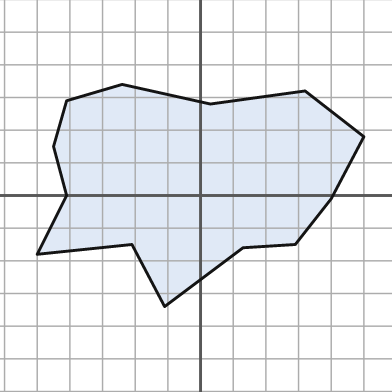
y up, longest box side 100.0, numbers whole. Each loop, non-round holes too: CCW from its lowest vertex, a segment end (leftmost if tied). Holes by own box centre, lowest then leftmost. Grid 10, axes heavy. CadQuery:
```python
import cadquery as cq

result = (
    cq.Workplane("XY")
    .moveTo(-11.0, -34.0)
    .lineTo(13.0, -16.0)
    .lineTo(29.0, -15.0)
    .lineTo(40.0, -1.0)
    .lineTo(50.0, 18.0)
    .lineTo(32.0, 32.0)
    .lineTo(3.0, 28.0)
    .lineTo(-24.0, 34.0)
    .lineTo(-41.0, 29.0)
    .lineTo(-45.0, 15.0)
    .lineTo(-41.0, 0.0)
    .lineTo(-50.0, -18.0)
    .lineTo(-21.0, -15.0)
    .close()
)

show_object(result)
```